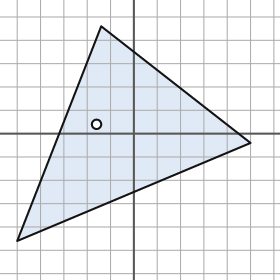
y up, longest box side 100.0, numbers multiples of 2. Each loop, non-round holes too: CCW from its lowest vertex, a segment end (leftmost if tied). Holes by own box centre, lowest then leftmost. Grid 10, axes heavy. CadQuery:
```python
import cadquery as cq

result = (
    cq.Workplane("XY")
    .moveTo(-50.0, -46.0)
    .lineTo(50.0, -4.0)
    .lineTo(-14.0, 46.0)
    .close()
    .moveTo(-16.0, 4.0)
    .circle(2.0)
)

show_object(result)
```